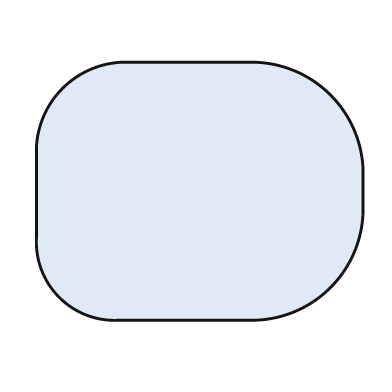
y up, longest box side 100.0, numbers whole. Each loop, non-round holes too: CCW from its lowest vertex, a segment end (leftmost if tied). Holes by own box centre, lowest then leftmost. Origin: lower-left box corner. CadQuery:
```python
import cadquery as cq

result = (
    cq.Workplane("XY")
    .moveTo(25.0, 0.0)
    .lineTo(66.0, 0.0)
    .threePointArc((90.0, 10.0), (100.0, 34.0))
    .lineTo(100.0, 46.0)
    .threePointArc((90.0, 69.0), (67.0, 79.0))
    .lineTo(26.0, 79.0)
    .threePointArc((8.0, 71.0), (0.0, 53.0))
    .lineTo(0.0, 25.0)
    .threePointArc((7.0, 7.0), (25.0, 0.0))
    .close()
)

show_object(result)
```